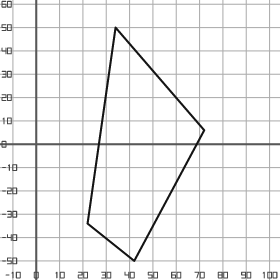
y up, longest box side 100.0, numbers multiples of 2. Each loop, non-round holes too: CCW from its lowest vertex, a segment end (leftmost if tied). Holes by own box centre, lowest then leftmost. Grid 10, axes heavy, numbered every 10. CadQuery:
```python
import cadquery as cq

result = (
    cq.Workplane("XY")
    .moveTo(42.0, -50.0)
    .lineTo(72.0, 6.0)
    .lineTo(34.0, 50.0)
    .lineTo(22.0, -34.0)
    .close()
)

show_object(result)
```